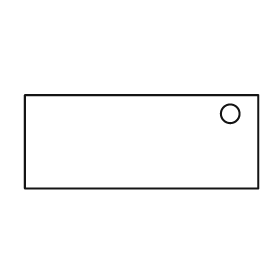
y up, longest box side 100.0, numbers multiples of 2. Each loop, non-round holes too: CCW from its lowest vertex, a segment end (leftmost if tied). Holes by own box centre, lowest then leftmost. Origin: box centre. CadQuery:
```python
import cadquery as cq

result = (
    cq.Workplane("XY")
    .moveTo(-50.0, -20.0)
    .lineTo(50.0, -20.0)
    .lineTo(50.0, 20.0)
    .lineTo(-50.0, 20.0)
    .close()
    .moveTo(38.0, 12.0)
    .circle(4.0)
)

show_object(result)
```